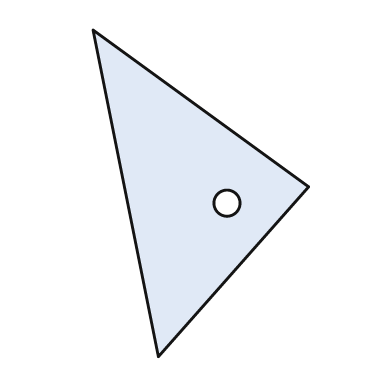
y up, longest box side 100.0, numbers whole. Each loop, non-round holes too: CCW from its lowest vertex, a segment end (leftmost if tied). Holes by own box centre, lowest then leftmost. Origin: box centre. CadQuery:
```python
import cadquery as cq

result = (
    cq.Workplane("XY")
    .moveTo(-13.0, -50.0)
    .lineTo(33.0, 2.0)
    .lineTo(-33.0, 50.0)
    .close()
    .moveTo(8.0, -3.0)
    .circle(4.0)
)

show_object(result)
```